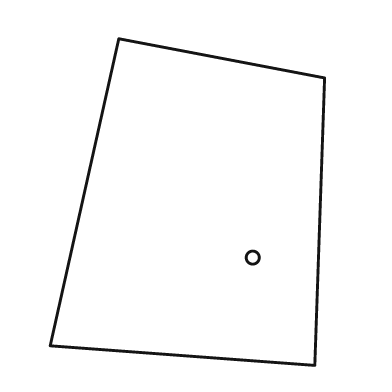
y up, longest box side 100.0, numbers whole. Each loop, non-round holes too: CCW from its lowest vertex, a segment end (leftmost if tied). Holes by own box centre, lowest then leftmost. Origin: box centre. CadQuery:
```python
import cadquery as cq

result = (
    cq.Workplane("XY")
    .moveTo(39.0, -50.0)
    .lineTo(42.0, 38.0)
    .lineTo(-21.0, 50.0)
    .lineTo(-42.0, -44.0)
    .close()
    .moveTo(20.0, -17.0)
    .circle(2.0)
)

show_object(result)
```